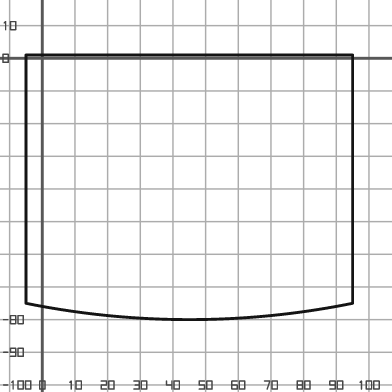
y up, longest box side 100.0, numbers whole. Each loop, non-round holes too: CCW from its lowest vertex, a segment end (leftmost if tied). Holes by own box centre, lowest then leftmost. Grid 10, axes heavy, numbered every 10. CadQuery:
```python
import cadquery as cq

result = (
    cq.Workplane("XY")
    .moveTo(-5.0, -75.0)
    .threePointArc((45.0, -80.0), (95.0, -75.0))
    .lineTo(95.0, 1.0)
    .lineTo(-5.0, 1.0)
    .close()
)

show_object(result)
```